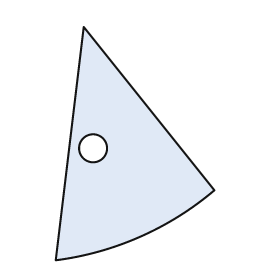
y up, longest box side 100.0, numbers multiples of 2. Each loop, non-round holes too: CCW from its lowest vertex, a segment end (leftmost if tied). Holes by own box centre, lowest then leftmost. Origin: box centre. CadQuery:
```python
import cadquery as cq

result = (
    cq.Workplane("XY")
    .moveTo(-34.0, -50.0)
    .threePointArc((2.0, -40.0), (34.0, -20.0))
    .lineTo(-22.0, 50.0)
    .close()
    .moveTo(-18.0, -2.0)
    .circle(6.0)
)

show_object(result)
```